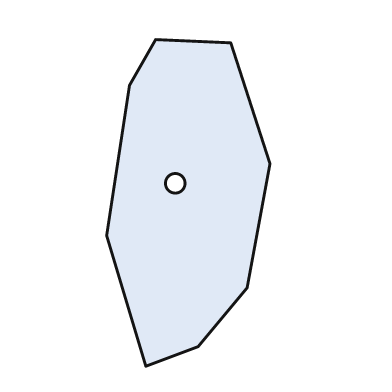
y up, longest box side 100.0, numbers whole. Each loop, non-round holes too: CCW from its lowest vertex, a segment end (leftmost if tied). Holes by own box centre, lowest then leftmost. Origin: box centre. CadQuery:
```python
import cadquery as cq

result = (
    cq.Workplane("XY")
    .moveTo(-13.0, -50.0)
    .lineTo(3.0, -44.0)
    .lineTo(18.0, -26.0)
    .lineTo(25.0, 12.0)
    .lineTo(13.0, 49.0)
    .lineTo(-10.0, 50.0)
    .lineTo(-18.0, 36.0)
    .lineTo(-25.0, -10.0)
    .close()
    .moveTo(-4.0, 6.0)
    .circle(3.0)
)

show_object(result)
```